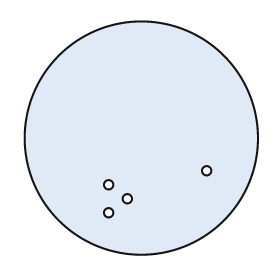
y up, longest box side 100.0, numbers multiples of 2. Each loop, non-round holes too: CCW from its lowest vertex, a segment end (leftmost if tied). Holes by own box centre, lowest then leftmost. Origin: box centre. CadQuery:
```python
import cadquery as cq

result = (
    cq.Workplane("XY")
    .moveTo(0.0, 0.0)
    .circle(50.0)
    .moveTo(-14.0, -32.0)
    .circle(2.0)
    .moveTo(-6.0, -26.0)
    .circle(2.0)
    .moveTo(-14.0, -20.0)
    .circle(2.0)
    .moveTo(28.0, -14.0)
    .circle(2.0)
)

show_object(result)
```